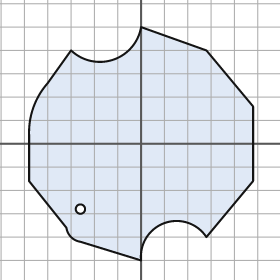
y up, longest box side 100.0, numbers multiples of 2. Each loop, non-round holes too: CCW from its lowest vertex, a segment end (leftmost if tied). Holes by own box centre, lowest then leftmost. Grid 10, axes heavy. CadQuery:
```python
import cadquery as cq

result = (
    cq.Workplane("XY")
    .moveTo(0.0, -50.0)
    .threePointArc((10.0, -34.0), (28.0, -40.0))
    .lineTo(48.0, -16.0)
    .lineTo(48.0, 16.0)
    .lineTo(28.0, 40.0)
    .lineTo(0.0, 50.0)
    .threePointArc((-12.0, 36.0), (-30.0, 40.0))
    .lineTo(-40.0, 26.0)
    .threePointArc((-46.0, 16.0), (-48.0, 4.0))
    .lineTo(-48.0, -16.0)
    .lineTo(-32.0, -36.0)
    .threePointArc((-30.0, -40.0), (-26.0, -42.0))
    .close()
    .moveTo(-26.0, -28.0)
    .circle(2.0)
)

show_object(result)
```